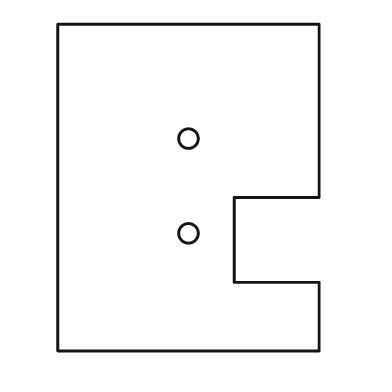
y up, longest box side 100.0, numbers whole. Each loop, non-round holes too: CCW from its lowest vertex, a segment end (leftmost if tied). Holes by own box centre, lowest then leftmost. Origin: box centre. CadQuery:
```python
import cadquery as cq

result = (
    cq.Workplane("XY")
    .moveTo(-40.0, -50.0)
    .lineTo(40.0, -50.0)
    .lineTo(40.0, -29.0)
    .lineTo(14.0, -29.0)
    .lineTo(14.0, -3.0)
    .lineTo(40.0, -3.0)
    .lineTo(40.0, 50.0)
    .lineTo(-40.0, 50.0)
    .close()
    .moveTo(0.0, -14.0)
    .circle(3.0)
    .moveTo(0.0, 15.0)
    .circle(3.0)
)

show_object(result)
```